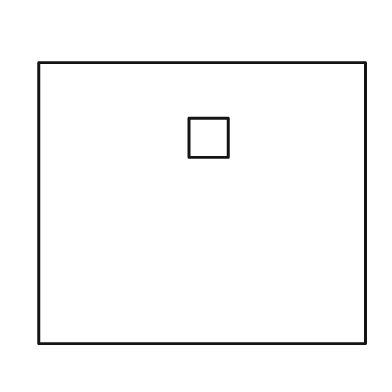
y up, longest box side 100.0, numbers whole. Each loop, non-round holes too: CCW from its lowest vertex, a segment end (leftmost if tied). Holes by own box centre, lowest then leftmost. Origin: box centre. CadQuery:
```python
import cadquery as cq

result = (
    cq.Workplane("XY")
    .moveTo(-50.0, -43.0)
    .lineTo(50.0, -43.0)
    .lineTo(50.0, 43.0)
    .lineTo(-50.0, 43.0)
    .close()
    .moveTo(-4.0, 14.0)
    .lineTo(8.0, 14.0)
    .lineTo(8.0, 26.0)
    .lineTo(-4.0, 26.0)
    .close()
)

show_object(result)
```